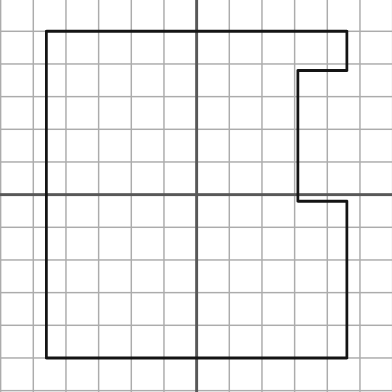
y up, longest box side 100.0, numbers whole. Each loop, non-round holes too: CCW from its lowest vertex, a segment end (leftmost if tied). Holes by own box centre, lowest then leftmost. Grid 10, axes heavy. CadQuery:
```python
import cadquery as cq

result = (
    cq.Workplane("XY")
    .moveTo(-46.0, -50.0)
    .lineTo(46.0, -50.0)
    .lineTo(46.0, -2.0)
    .lineTo(31.0, -2.0)
    .lineTo(31.0, 38.0)
    .lineTo(46.0, 38.0)
    .lineTo(46.0, 50.0)
    .lineTo(-46.0, 50.0)
    .close()
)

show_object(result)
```